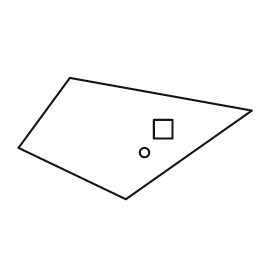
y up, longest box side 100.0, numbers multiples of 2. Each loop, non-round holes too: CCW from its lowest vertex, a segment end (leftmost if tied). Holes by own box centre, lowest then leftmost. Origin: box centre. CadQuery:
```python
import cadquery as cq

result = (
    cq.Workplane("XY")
    .moveTo(-4.0, -26.0)
    .lineTo(50.0, 12.0)
    .lineTo(-28.0, 26.0)
    .lineTo(-50.0, -4.0)
    .close()
    .moveTo(4.0, -6.0)
    .circle(2.0)
    .moveTo(8.0, 0.0)
    .lineTo(16.0, 0.0)
    .lineTo(16.0, 8.0)
    .lineTo(8.0, 8.0)
    .close()
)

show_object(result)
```